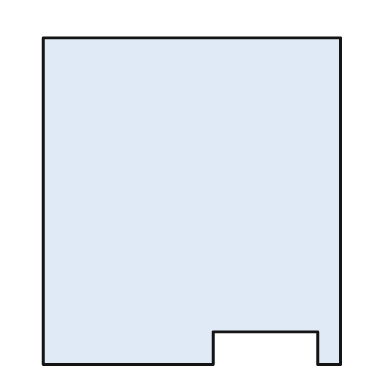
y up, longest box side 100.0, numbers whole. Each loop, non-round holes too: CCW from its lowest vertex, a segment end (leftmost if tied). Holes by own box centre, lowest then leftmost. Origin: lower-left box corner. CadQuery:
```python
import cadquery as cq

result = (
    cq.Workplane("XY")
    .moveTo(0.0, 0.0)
    .lineTo(52.0, 0.0)
    .lineTo(52.0, 10.0)
    .lineTo(84.0, 10.0)
    .lineTo(84.0, 0.0)
    .lineTo(91.0, 0.0)
    .lineTo(91.0, 100.0)
    .lineTo(0.0, 100.0)
    .close()
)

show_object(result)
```